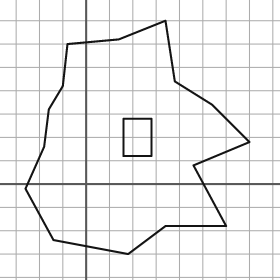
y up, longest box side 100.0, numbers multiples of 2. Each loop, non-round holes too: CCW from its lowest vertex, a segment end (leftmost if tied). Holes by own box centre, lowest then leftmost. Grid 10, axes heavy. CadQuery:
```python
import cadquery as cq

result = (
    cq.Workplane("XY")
    .moveTo(18.0, -30.0)
    .lineTo(34.0, -18.0)
    .lineTo(60.0, -18.0)
    .lineTo(46.0, 8.0)
    .lineTo(70.0, 18.0)
    .lineTo(54.0, 34.0)
    .lineTo(38.0, 44.0)
    .lineTo(34.0, 70.0)
    .lineTo(14.0, 62.0)
    .lineTo(-8.0, 60.0)
    .lineTo(-10.0, 42.0)
    .lineTo(-16.0, 32.0)
    .lineTo(-18.0, 16.0)
    .lineTo(-26.0, -2.0)
    .lineTo(-14.0, -24.0)
    .close()
    .moveTo(16.0, 12.0)
    .lineTo(28.0, 12.0)
    .lineTo(28.0, 28.0)
    .lineTo(16.0, 28.0)
    .close()
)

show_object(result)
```